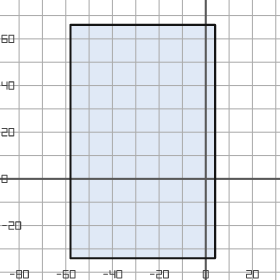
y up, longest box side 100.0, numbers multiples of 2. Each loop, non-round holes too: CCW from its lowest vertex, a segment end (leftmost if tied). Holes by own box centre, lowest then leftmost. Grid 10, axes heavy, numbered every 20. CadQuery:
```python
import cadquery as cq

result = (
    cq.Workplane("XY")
    .moveTo(-58.0, -34.0)
    .lineTo(4.0, -34.0)
    .lineTo(4.0, 66.0)
    .lineTo(-58.0, 66.0)
    .close()
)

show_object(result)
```